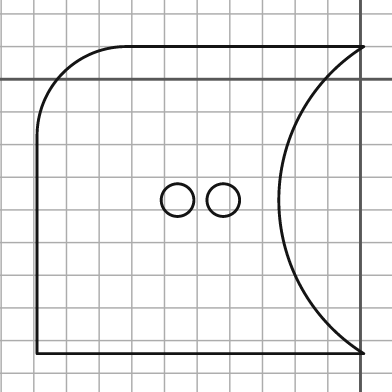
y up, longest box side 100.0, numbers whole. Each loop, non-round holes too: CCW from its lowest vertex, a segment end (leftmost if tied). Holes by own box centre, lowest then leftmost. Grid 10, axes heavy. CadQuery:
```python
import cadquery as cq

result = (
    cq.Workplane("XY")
    .moveTo(-99.0, -84.0)
    .lineTo(1.0, -84.0)
    .threePointArc((-25.0, -37.0), (1.0, 10.0))
    .lineTo(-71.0, 10.0)
    .threePointArc((-91.0, 2.0), (-99.0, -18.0))
    .close()
    .moveTo(-56.0, -37.0)
    .circle(5.0)
    .moveTo(-42.0, -37.0)
    .circle(5.0)
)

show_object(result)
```